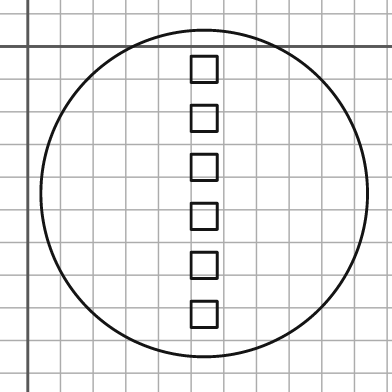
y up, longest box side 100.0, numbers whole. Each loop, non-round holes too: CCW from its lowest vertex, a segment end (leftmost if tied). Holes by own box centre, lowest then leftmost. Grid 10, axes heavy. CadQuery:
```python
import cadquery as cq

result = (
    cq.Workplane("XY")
    .moveTo(54.0, -45.0)
    .circle(50.0)
    .moveTo(50.0, -86.0)
    .lineTo(58.0, -86.0)
    .lineTo(58.0, -78.0)
    .lineTo(50.0, -78.0)
    .close()
    .moveTo(50.0, -71.0)
    .lineTo(58.0, -71.0)
    .lineTo(58.0, -63.0)
    .lineTo(50.0, -63.0)
    .close()
    .moveTo(50.0, -56.0)
    .lineTo(58.0, -56.0)
    .lineTo(58.0, -48.0)
    .lineTo(50.0, -48.0)
    .close()
    .moveTo(50.0, -41.0)
    .lineTo(58.0, -41.0)
    .lineTo(58.0, -33.0)
    .lineTo(50.0, -33.0)
    .close()
    .moveTo(50.0, -26.0)
    .lineTo(58.0, -26.0)
    .lineTo(58.0, -18.0)
    .lineTo(50.0, -18.0)
    .close()
    .moveTo(50.0, -11.0)
    .lineTo(58.0, -11.0)
    .lineTo(58.0, -3.0)
    .lineTo(50.0, -3.0)
    .close()
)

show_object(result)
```